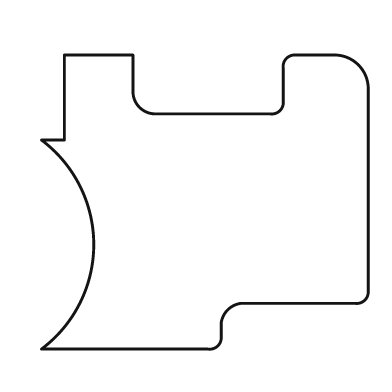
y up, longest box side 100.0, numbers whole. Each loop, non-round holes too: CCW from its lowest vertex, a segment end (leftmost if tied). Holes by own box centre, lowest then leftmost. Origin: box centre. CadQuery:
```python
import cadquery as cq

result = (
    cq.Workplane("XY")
    .moveTo(-50.0, -45.0)
    .lineTo(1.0, -45.0)
    .threePointArc((4.0, -44.0), (5.0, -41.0))
    .lineTo(5.0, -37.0)
    .threePointArc((7.0, -33.0), (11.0, -31.0))
    .lineTo(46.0, -31.0)
    .threePointArc((49.0, -30.0), (50.0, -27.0))
    .lineTo(50.0, 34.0)
    .threePointArc((47.0, 42.0), (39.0, 45.0))
    .lineTo(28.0, 45.0)
    .threePointArc((25.0, 44.0), (24.0, 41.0))
    .lineTo(24.0, 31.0)
    .threePointArc((23.0, 28.0), (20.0, 27.0))
    .lineTo(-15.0, 27.0)
    .threePointArc((-20.0, 29.0), (-22.0, 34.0))
    .lineTo(-22.0, 45.0)
    .lineTo(-43.0, 45.0)
    .lineTo(-43.0, 19.0)
    .lineTo(-50.0, 19.0)
    .threePointArc((-34.0, -13.0), (-50.0, -45.0))
    .close()
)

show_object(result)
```